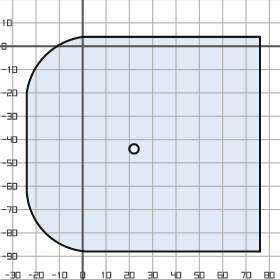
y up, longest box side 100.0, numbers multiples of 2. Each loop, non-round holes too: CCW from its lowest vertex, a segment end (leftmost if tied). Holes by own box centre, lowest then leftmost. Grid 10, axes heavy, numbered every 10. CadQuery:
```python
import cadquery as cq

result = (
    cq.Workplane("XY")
    .moveTo(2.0, -88.0)
    .lineTo(76.0, -88.0)
    .lineTo(76.0, 4.0)
    .lineTo(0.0, 4.0)
    .threePointArc((-16.0, -4.0), (-24.0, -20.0))
    .lineTo(-24.0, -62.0)
    .threePointArc((-16.0, -80.0), (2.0, -88.0))
    .close()
    .moveTo(22.0, -44.0)
    .circle(2.0)
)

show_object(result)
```